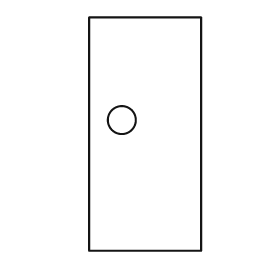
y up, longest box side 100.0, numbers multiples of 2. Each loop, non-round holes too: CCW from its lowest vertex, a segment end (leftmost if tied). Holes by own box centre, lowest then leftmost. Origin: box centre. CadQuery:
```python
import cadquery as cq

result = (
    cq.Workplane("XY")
    .moveTo(-24.0, -50.0)
    .lineTo(24.0, -50.0)
    .lineTo(24.0, 50.0)
    .lineTo(-24.0, 50.0)
    .close()
    .moveTo(-10.0, 6.0)
    .circle(6.0)
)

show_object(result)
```